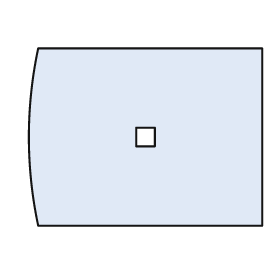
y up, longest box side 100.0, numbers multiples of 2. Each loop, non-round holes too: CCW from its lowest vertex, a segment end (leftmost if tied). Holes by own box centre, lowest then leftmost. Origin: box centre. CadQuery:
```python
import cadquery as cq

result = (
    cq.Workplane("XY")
    .moveTo(-46.0, -38.0)
    .lineTo(50.0, -38.0)
    .lineTo(50.0, 38.0)
    .lineTo(-46.0, 38.0)
    .threePointArc((-50.0, 0.0), (-46.0, -38.0))
    .close()
    .moveTo(-4.0, -4.0)
    .lineTo(4.0, -4.0)
    .lineTo(4.0, 4.0)
    .lineTo(-4.0, 4.0)
    .close()
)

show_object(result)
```